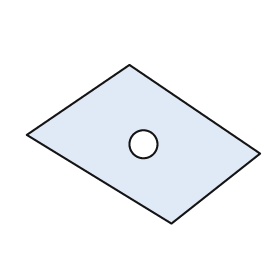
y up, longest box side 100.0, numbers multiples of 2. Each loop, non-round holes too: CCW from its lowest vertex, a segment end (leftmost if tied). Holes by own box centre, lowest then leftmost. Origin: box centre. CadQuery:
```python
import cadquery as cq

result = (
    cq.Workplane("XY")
    .moveTo(12.0, -34.0)
    .lineTo(50.0, -4.0)
    .lineTo(-6.0, 34.0)
    .lineTo(-50.0, 4.0)
    .close()
    .moveTo(0.0, 0.0)
    .circle(6.0)
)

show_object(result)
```